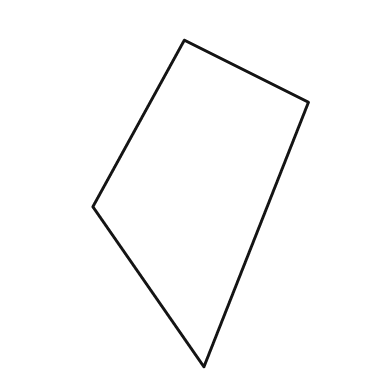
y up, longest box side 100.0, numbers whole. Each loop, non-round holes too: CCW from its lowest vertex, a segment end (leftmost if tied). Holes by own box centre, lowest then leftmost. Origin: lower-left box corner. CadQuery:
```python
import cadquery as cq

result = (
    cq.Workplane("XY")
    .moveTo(34.0, 0.0)
    .lineTo(66.0, 81.0)
    .lineTo(28.0, 100.0)
    .lineTo(0.0, 49.0)
    .close()
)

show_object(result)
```